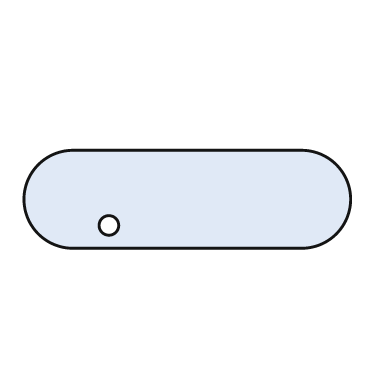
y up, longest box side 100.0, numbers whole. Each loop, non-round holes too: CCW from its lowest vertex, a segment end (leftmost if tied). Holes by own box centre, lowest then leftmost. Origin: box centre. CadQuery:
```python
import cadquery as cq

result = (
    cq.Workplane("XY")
    .moveTo(-35.0, -15.0)
    .lineTo(35.0, -15.0)
    .threePointArc((50.0, 0.0), (35.0, 15.0))
    .lineTo(-35.0, 15.0)
    .threePointArc((-50.0, 0.0), (-35.0, -15.0))
    .close()
    .moveTo(-24.0, -8.0)
    .circle(3.0)
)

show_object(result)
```